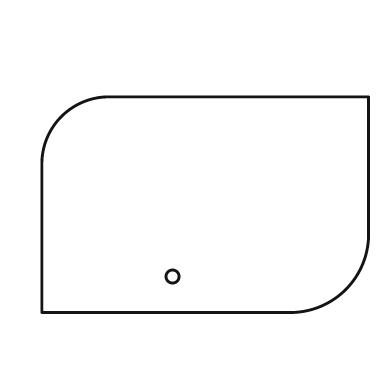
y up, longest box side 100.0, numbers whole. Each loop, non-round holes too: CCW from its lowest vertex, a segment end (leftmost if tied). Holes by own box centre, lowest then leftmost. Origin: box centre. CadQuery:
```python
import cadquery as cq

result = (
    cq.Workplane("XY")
    .moveTo(-50.0, -33.0)
    .lineTo(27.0, -33.0)
    .threePointArc((43.0, -26.0), (50.0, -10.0))
    .lineTo(50.0, 33.0)
    .lineTo(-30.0, 33.0)
    .threePointArc((-44.0, 27.0), (-50.0, 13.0))
    .close()
    .moveTo(-10.0, -22.0)
    .circle(2.0)
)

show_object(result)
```